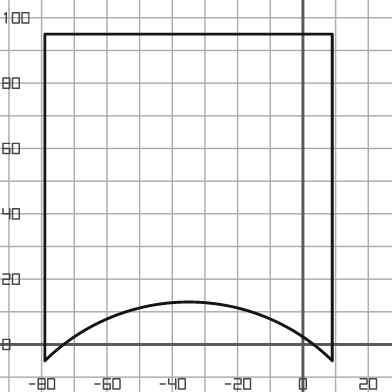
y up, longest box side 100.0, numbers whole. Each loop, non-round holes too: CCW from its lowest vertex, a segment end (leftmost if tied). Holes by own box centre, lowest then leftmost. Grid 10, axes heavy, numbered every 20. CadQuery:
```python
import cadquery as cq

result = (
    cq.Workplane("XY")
    .moveTo(-79.0, -5.0)
    .threePointArc((-35.0, 13.0), (9.0, -5.0))
    .lineTo(9.0, 95.0)
    .lineTo(-79.0, 95.0)
    .close()
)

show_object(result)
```